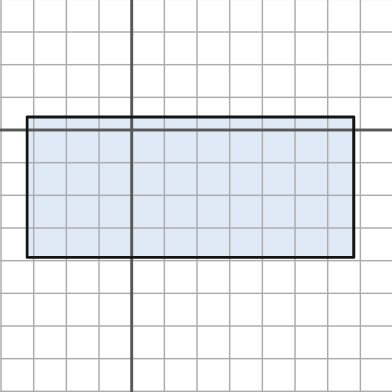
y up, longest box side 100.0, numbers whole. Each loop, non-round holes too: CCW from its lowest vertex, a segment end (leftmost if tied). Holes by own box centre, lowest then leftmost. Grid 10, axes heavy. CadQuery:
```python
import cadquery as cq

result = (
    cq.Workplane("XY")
    .moveTo(-32.0, -39.0)
    .lineTo(68.0, -39.0)
    .lineTo(68.0, 4.0)
    .lineTo(-32.0, 4.0)
    .close()
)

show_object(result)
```